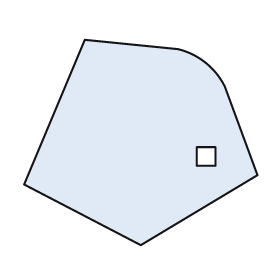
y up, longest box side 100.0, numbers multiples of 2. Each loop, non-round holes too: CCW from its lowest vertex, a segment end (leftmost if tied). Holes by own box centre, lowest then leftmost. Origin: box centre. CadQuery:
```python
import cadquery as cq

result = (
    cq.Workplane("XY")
    .moveTo(0.0, -44.0)
    .lineTo(50.0, -14.0)
    .lineTo(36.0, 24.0)
    .threePointArc((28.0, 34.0), (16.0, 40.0))
    .lineTo(-24.0, 44.0)
    .lineTo(-50.0, -18.0)
    .close()
    .moveTo(24.0, -10.0)
    .lineTo(32.0, -10.0)
    .lineTo(32.0, -2.0)
    .lineTo(24.0, -2.0)
    .close()
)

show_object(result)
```